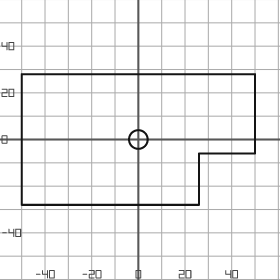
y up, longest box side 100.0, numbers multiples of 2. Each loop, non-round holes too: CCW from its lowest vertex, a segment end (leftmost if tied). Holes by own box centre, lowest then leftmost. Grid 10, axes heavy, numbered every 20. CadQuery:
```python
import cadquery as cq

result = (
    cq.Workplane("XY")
    .moveTo(-50.0, -28.0)
    .lineTo(26.0, -28.0)
    .lineTo(26.0, -6.0)
    .lineTo(50.0, -6.0)
    .lineTo(50.0, 28.0)
    .lineTo(-50.0, 28.0)
    .close()
    .moveTo(0.0, 0.0)
    .circle(4.0)
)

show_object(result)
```